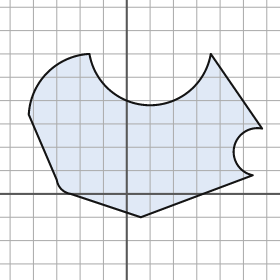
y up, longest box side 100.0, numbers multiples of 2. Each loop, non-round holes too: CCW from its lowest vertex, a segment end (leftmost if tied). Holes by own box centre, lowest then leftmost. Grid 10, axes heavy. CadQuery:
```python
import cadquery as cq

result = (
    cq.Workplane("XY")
    .moveTo(6.0, -10.0)
    .lineTo(54.0, 8.0)
    .threePointArc((46.0, 20.0), (58.0, 28.0))
    .lineTo(36.0, 60.0)
    .threePointArc((10.0, 38.0), (-16.0, 60.0))
    .threePointArc((-34.0, 52.0), (-42.0, 34.0))
    .lineTo(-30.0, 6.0)
    .threePointArc((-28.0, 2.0), (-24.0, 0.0))
    .close()
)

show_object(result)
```